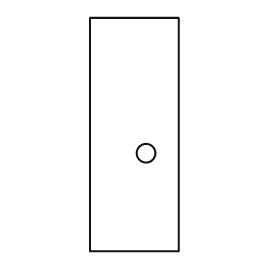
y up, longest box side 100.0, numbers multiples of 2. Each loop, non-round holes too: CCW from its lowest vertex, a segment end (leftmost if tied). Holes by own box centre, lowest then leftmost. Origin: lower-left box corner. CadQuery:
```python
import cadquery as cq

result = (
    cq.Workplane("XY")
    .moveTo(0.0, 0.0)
    .lineTo(38.0, 0.0)
    .lineTo(38.0, 100.0)
    .lineTo(0.0, 100.0)
    .close()
    .moveTo(24.0, 42.0)
    .circle(4.0)
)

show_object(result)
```